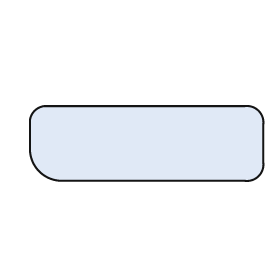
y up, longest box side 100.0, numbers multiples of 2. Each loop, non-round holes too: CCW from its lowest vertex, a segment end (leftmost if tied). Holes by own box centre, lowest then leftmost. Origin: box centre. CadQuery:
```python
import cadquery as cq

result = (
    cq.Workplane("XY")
    .moveTo(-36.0, -16.0)
    .lineTo(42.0, -16.0)
    .threePointArc((48.0, -14.0), (50.0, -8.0))
    .lineTo(50.0, 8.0)
    .threePointArc((48.0, 14.0), (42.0, 16.0))
    .lineTo(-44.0, 16.0)
    .threePointArc((-48.0, 14.0), (-50.0, 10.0))
    .lineTo(-50.0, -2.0)
    .threePointArc((-46.0, -12.0), (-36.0, -16.0))
    .close()
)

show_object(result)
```